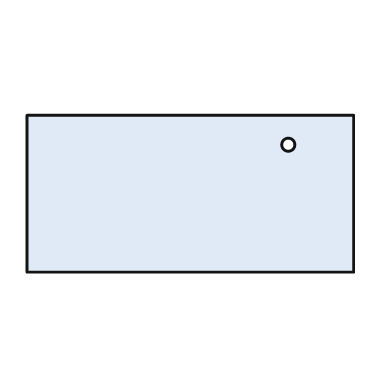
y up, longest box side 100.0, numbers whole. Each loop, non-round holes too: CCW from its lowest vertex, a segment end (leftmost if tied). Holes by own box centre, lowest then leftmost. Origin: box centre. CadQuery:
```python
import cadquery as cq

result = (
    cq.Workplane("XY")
    .moveTo(-50.0, -24.0)
    .lineTo(50.0, -24.0)
    .lineTo(50.0, 24.0)
    .lineTo(-50.0, 24.0)
    .close()
    .moveTo(30.0, 15.0)
    .circle(2.0)
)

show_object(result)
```